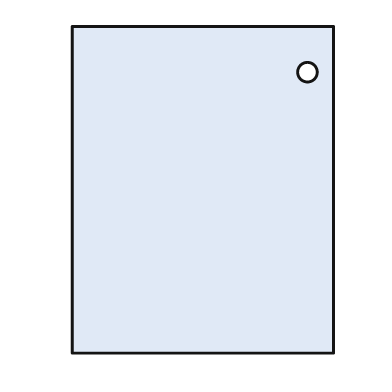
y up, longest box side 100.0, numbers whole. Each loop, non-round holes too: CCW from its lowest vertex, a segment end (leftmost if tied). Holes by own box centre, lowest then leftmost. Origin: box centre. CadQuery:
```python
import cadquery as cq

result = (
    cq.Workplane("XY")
    .moveTo(-40.0, -50.0)
    .lineTo(40.0, -50.0)
    .lineTo(40.0, 50.0)
    .lineTo(-40.0, 50.0)
    .close()
    .moveTo(32.0, 36.0)
    .circle(3.0)
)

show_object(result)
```